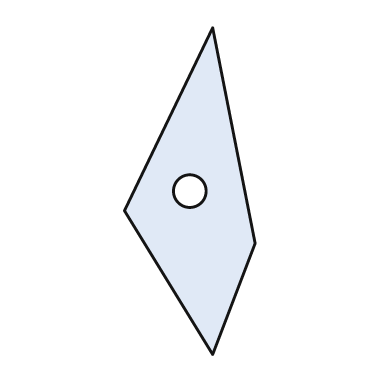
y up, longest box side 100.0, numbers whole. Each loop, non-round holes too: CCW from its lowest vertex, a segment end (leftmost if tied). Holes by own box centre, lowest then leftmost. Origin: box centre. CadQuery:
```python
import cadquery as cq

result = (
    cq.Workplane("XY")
    .moveTo(7.0, -50.0)
    .lineTo(20.0, -16.0)
    .lineTo(7.0, 50.0)
    .lineTo(-20.0, -6.0)
    .close()
    .moveTo(0.0, 0.0)
    .circle(5.0)
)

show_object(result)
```